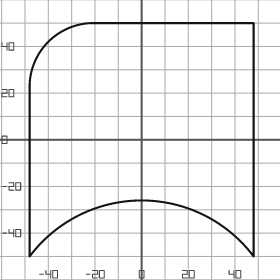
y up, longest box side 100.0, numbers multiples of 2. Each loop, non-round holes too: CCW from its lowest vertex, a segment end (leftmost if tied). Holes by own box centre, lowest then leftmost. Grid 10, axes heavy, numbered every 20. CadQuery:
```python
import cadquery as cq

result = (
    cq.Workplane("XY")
    .moveTo(-48.0, -50.0)
    .threePointArc((0.0, -26.0), (48.0, -50.0))
    .lineTo(48.0, 50.0)
    .lineTo(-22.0, 50.0)
    .threePointArc((-40.0, 42.0), (-48.0, 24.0))
    .close()
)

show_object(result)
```